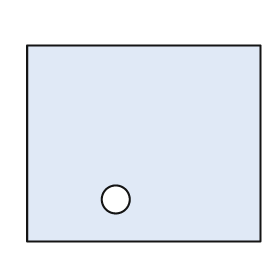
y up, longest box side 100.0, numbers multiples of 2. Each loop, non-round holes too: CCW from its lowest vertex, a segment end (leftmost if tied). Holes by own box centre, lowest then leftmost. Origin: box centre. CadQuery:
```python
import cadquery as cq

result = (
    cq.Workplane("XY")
    .moveTo(-50.0, -42.0)
    .lineTo(50.0, -42.0)
    .lineTo(50.0, 42.0)
    .lineTo(-50.0, 42.0)
    .close()
    .moveTo(-12.0, -24.0)
    .circle(6.0)
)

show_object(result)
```